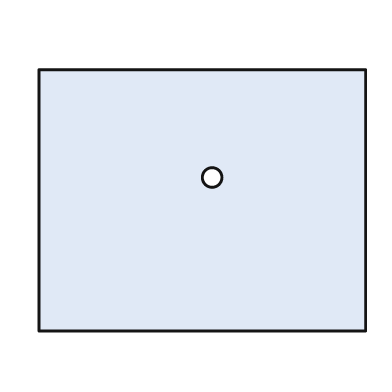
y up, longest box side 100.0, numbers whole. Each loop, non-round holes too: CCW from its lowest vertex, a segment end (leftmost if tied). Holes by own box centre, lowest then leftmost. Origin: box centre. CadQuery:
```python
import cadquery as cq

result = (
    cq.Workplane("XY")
    .moveTo(-50.0, -40.0)
    .lineTo(50.0, -40.0)
    .lineTo(50.0, 40.0)
    .lineTo(-50.0, 40.0)
    .close()
    .moveTo(3.0, 7.0)
    .circle(3.0)
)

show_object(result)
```